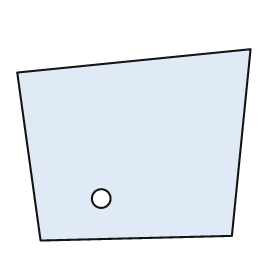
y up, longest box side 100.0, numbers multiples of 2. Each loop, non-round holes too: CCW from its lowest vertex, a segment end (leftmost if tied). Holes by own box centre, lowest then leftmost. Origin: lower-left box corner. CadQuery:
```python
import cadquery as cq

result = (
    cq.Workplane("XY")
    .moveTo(10.0, 0.0)
    .lineTo(92.0, 2.0)
    .lineTo(100.0, 82.0)
    .lineTo(0.0, 72.0)
    .close()
    .moveTo(36.0, 18.0)
    .circle(4.0)
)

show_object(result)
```